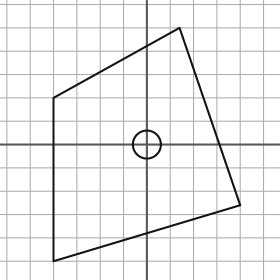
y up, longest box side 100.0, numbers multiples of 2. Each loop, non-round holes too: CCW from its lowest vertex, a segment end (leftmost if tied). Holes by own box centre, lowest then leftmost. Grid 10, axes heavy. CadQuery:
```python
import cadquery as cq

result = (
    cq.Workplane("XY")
    .moveTo(-40.0, -50.0)
    .lineTo(40.0, -26.0)
    .lineTo(14.0, 50.0)
    .lineTo(-40.0, 20.0)
    .close()
    .moveTo(0.0, 0.0)
    .circle(6.0)
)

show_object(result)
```